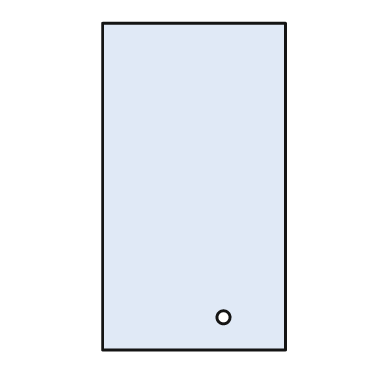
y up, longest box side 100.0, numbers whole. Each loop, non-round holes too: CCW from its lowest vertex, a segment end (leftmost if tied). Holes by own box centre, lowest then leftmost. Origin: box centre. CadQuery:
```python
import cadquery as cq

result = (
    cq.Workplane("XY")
    .moveTo(-28.0, -50.0)
    .lineTo(28.0, -50.0)
    .lineTo(28.0, 50.0)
    .lineTo(-28.0, 50.0)
    .close()
    .moveTo(9.0, -40.0)
    .circle(2.0)
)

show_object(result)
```